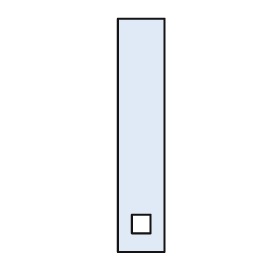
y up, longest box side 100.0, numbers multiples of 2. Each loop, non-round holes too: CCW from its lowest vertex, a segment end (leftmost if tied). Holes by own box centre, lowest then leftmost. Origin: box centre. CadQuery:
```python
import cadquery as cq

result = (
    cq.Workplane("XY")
    .moveTo(-10.0, -50.0)
    .lineTo(10.0, -50.0)
    .lineTo(10.0, 50.0)
    .lineTo(-10.0, 50.0)
    .close()
    .moveTo(-4.0, -42.0)
    .lineTo(4.0, -42.0)
    .lineTo(4.0, -34.0)
    .lineTo(-4.0, -34.0)
    .close()
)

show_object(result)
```